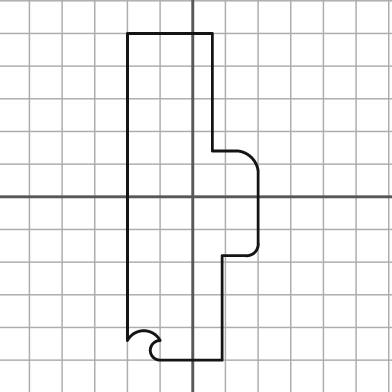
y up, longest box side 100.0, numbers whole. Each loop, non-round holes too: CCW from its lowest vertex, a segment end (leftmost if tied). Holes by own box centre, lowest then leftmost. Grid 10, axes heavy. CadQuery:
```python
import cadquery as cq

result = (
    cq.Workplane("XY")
    .moveTo(-10.0, -50.0)
    .lineTo(9.0, -50.0)
    .lineTo(9.0, -18.0)
    .lineTo(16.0, -18.0)
    .threePointArc((19.0, -17.0), (20.0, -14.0))
    .lineTo(20.0, 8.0)
    .threePointArc((18.0, 12.0), (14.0, 14.0))
    .lineTo(6.0, 14.0)
    .lineTo(6.0, 50.0)
    .lineTo(-20.0, 50.0)
    .lineTo(-20.0, -44.0)
    .threePointArc((-15.0, -41.0), (-10.0, -44.0))
    .threePointArc((-13.0, -47.0), (-10.0, -50.0))
    .close()
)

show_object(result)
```